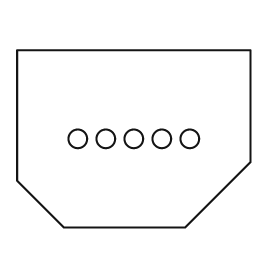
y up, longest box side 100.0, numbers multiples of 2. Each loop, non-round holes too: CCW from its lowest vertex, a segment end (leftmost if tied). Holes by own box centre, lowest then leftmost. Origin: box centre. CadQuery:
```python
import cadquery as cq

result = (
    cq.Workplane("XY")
    .moveTo(-30.0, -38.0)
    .lineTo(22.0, -38.0)
    .lineTo(50.0, -10.0)
    .lineTo(50.0, 38.0)
    .lineTo(-50.0, 38.0)
    .lineTo(-50.0, -18.0)
    .close()
    .moveTo(-24.0, 0.0)
    .circle(4.0)
    .moveTo(-12.0, 0.0)
    .circle(4.0)
    .moveTo(0.0, 0.0)
    .circle(4.0)
    .moveTo(12.0, 0.0)
    .circle(4.0)
    .moveTo(24.0, 0.0)
    .circle(4.0)
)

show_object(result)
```